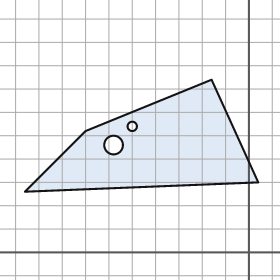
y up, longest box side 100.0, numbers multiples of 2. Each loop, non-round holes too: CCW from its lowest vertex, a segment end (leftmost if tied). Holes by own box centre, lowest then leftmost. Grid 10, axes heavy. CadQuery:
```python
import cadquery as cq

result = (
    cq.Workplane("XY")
    .moveTo(-96.0, 26.0)
    .lineTo(4.0, 30.0)
    .lineTo(-16.0, 74.0)
    .lineTo(-70.0, 52.0)
    .close()
    .moveTo(-58.0, 46.0)
    .circle(4.0)
    .moveTo(-50.0, 54.0)
    .circle(2.0)
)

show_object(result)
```